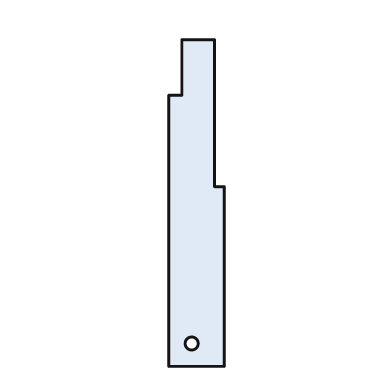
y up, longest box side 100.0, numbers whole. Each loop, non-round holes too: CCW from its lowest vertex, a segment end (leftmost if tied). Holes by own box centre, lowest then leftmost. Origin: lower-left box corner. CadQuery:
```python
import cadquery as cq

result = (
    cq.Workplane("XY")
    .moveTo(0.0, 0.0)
    .lineTo(17.0, 0.0)
    .lineTo(17.0, 55.0)
    .lineTo(14.0, 55.0)
    .lineTo(14.0, 100.0)
    .lineTo(4.0, 100.0)
    .lineTo(4.0, 83.0)
    .lineTo(0.0, 83.0)
    .close()
    .moveTo(7.0, 7.0)
    .circle(2.0)
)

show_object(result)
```